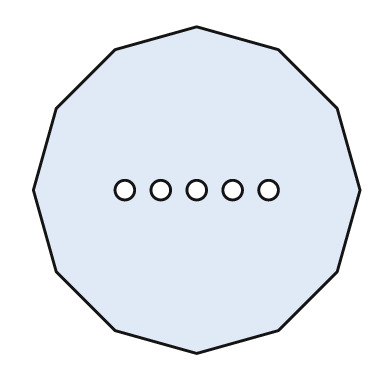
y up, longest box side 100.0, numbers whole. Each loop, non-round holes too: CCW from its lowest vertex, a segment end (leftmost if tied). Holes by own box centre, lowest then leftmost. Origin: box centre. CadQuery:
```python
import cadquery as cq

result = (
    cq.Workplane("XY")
    .moveTo(0.0, -50.0)
    .lineTo(25.0, -43.0)
    .lineTo(43.0, -25.0)
    .lineTo(50.0, 0.0)
    .lineTo(43.0, 25.0)
    .lineTo(25.0, 43.0)
    .lineTo(0.0, 50.0)
    .lineTo(-25.0, 43.0)
    .lineTo(-43.0, 25.0)
    .lineTo(-50.0, 0.0)
    .lineTo(-43.0, -25.0)
    .lineTo(-25.0, -43.0)
    .close()
    .moveTo(-22.0, 0.0)
    .circle(3.0)
    .moveTo(-11.0, 0.0)
    .circle(3.0)
    .moveTo(0.0, 0.0)
    .circle(3.0)
    .moveTo(11.0, 0.0)
    .circle(3.0)
    .moveTo(22.0, 0.0)
    .circle(3.0)
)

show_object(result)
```